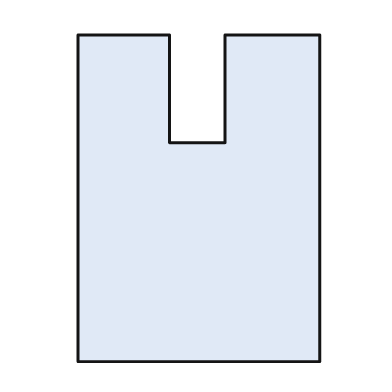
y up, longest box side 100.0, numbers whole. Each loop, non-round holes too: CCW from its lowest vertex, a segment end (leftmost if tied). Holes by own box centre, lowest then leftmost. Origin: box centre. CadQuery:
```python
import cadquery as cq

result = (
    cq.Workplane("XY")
    .moveTo(-37.0, -50.0)
    .lineTo(37.0, -50.0)
    .lineTo(37.0, 50.0)
    .lineTo(8.0, 50.0)
    .lineTo(8.0, 17.0)
    .lineTo(-9.0, 17.0)
    .lineTo(-9.0, 50.0)
    .lineTo(-37.0, 50.0)
    .close()
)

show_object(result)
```